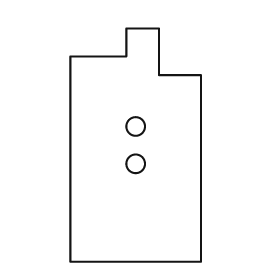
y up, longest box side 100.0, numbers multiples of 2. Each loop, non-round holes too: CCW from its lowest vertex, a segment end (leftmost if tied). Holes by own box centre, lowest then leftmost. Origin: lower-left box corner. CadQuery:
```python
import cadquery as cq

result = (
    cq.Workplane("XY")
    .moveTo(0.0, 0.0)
    .lineTo(56.0, 0.0)
    .lineTo(56.0, 80.0)
    .lineTo(38.0, 80.0)
    .lineTo(38.0, 100.0)
    .lineTo(24.0, 100.0)
    .lineTo(24.0, 88.0)
    .lineTo(0.0, 88.0)
    .close()
    .moveTo(28.0, 42.0)
    .circle(4.0)
    .moveTo(28.0, 58.0)
    .circle(4.0)
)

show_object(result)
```